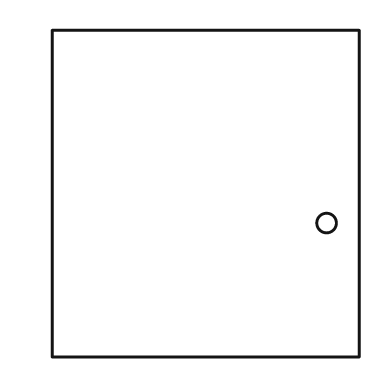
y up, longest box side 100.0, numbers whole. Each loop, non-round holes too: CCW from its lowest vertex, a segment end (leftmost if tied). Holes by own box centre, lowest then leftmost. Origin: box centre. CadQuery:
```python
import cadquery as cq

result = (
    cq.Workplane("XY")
    .moveTo(-47.0, -50.0)
    .lineTo(47.0, -50.0)
    .lineTo(47.0, 50.0)
    .lineTo(-47.0, 50.0)
    .close()
    .moveTo(37.0, -9.0)
    .circle(3.0)
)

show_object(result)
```